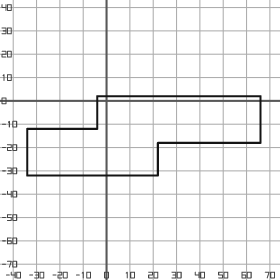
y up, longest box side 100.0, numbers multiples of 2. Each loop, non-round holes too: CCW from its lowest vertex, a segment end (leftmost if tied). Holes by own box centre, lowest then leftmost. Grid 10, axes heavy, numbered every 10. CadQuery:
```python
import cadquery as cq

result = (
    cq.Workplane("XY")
    .moveTo(-34.0, -32.0)
    .lineTo(22.0, -32.0)
    .lineTo(22.0, -18.0)
    .lineTo(66.0, -18.0)
    .lineTo(66.0, 2.0)
    .lineTo(-4.0, 2.0)
    .lineTo(-4.0, -12.0)
    .lineTo(-34.0, -12.0)
    .close()
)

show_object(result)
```